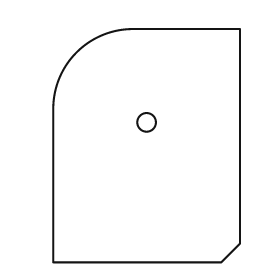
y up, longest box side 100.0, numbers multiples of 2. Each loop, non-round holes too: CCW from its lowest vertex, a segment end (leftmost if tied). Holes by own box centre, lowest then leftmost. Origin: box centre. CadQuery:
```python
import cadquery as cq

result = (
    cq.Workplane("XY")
    .moveTo(-40.0, -50.0)
    .lineTo(32.0, -50.0)
    .lineTo(40.0, -42.0)
    .lineTo(40.0, 50.0)
    .lineTo(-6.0, 50.0)
    .threePointArc((-30.0, 40.0), (-40.0, 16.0))
    .close()
    .moveTo(0.0, 10.0)
    .circle(4.0)
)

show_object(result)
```